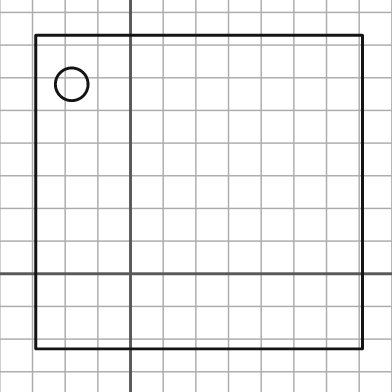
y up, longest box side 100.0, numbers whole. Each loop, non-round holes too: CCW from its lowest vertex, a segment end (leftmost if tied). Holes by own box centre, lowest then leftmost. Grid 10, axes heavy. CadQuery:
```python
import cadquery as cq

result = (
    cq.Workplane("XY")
    .moveTo(-29.0, -23.0)
    .lineTo(71.0, -23.0)
    .lineTo(71.0, 73.0)
    .lineTo(-29.0, 73.0)
    .close()
    .moveTo(-18.0, 58.0)
    .circle(5.0)
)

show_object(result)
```